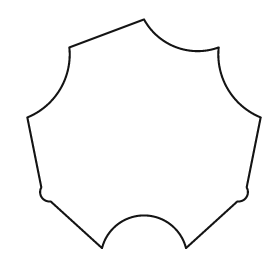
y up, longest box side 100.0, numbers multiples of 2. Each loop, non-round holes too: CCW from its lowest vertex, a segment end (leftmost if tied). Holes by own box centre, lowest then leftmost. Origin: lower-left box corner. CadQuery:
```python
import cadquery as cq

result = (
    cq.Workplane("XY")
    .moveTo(32.0, 0.0)
    .threePointArc((50.0, 14.0), (68.0, 0.0))
    .lineTo(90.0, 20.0)
    .threePointArc((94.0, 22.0), (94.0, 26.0))
    .lineTo(100.0, 56.0)
    .threePointArc((86.0, 68.0), (82.0, 86.0))
    .threePointArc((64.0, 86.0), (50.0, 98.0))
    .lineTo(18.0, 86.0)
    .threePointArc((14.0, 68.0), (0.0, 56.0))
    .lineTo(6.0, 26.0)
    .threePointArc((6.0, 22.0), (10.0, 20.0))
    .close()
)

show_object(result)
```